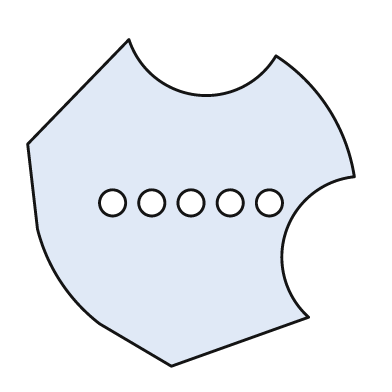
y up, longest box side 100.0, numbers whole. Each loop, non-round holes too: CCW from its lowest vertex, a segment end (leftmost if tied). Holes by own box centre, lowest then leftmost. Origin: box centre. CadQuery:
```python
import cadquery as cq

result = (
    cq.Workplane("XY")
    .moveTo(-6.0, -50.0)
    .lineTo(36.0, -35.0)
    .threePointArc((29.0, -9.0), (50.0, 8.0))
    .threePointArc((42.0, 29.0), (26.0, 45.0))
    .threePointArc((2.0, 33.0), (-19.0, 50.0))
    .lineTo(-50.0, 18.0)
    .lineTo(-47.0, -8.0)
    .threePointArc((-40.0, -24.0), (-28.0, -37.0))
    .close()
    .moveTo(-24.0, 0.0)
    .circle(4.0)
    .moveTo(-12.0, 0.0)
    .circle(4.0)
    .moveTo(0.0, 0.0)
    .circle(4.0)
    .moveTo(12.0, 0.0)
    .circle(4.0)
    .moveTo(24.0, 0.0)
    .circle(4.0)
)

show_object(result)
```